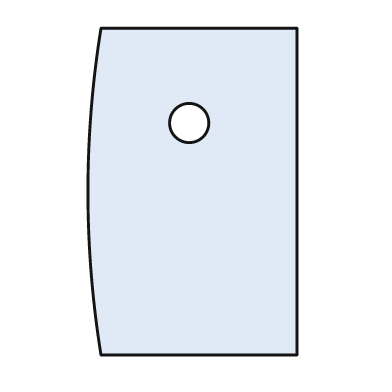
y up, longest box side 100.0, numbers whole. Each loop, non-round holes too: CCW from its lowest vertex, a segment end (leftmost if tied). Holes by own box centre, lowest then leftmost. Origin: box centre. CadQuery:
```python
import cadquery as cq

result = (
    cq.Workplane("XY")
    .moveTo(-28.0, -50.0)
    .lineTo(32.0, -50.0)
    .lineTo(32.0, 50.0)
    .lineTo(-28.0, 50.0)
    .threePointArc((-32.0, 0.0), (-28.0, -50.0))
    .close()
    .moveTo(-1.0, 21.0)
    .circle(6.0)
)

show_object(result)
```